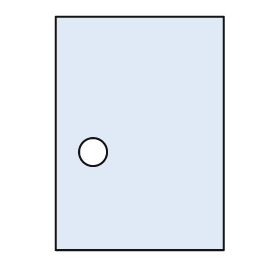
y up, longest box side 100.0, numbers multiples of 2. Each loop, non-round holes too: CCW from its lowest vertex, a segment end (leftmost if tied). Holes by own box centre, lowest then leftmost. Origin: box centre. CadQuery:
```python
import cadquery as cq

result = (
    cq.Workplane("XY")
    .moveTo(-36.0, -50.0)
    .lineTo(36.0, -50.0)
    .lineTo(36.0, 50.0)
    .lineTo(-36.0, 50.0)
    .close()
    .moveTo(-20.0, -8.0)
    .circle(6.0)
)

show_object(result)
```